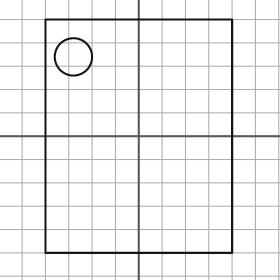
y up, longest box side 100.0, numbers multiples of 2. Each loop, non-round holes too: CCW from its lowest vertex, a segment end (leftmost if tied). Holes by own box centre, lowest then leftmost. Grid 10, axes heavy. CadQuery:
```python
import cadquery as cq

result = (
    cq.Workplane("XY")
    .moveTo(-40.0, -50.0)
    .lineTo(40.0, -50.0)
    .lineTo(40.0, 50.0)
    .lineTo(-40.0, 50.0)
    .close()
    .moveTo(-28.0, 34.0)
    .circle(8.0)
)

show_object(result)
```